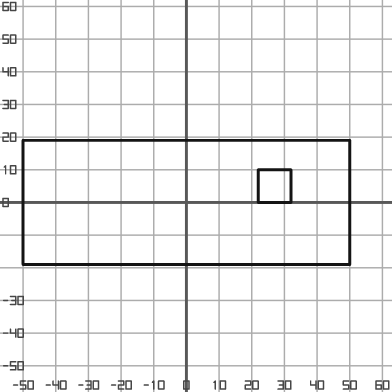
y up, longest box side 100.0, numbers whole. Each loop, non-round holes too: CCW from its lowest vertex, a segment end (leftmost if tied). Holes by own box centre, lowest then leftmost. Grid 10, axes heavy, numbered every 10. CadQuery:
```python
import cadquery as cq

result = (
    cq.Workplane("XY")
    .moveTo(-50.0, -19.0)
    .lineTo(50.0, -19.0)
    .lineTo(50.0, 19.0)
    .lineTo(-50.0, 19.0)
    .close()
    .moveTo(22.0, 0.0)
    .lineTo(32.0, 0.0)
    .lineTo(32.0, 10.0)
    .lineTo(22.0, 10.0)
    .close()
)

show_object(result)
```